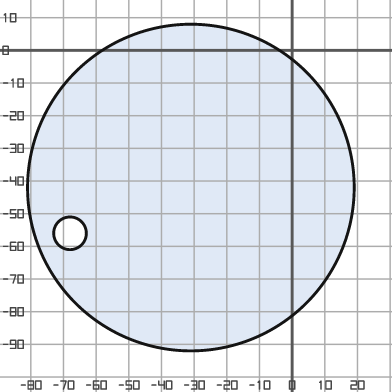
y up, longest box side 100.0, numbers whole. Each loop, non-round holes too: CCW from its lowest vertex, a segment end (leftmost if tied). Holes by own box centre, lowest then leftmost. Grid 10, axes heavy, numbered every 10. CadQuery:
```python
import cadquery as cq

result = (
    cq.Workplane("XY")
    .moveTo(-31.0, -42.0)
    .circle(50.0)
    .moveTo(-68.0, -56.0)
    .circle(5.0)
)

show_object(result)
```